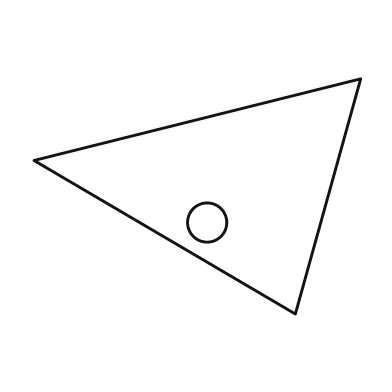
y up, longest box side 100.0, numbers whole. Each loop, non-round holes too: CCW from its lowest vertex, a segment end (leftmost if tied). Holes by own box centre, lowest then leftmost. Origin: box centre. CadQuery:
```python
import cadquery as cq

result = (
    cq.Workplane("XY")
    .moveTo(30.0, -36.0)
    .lineTo(50.0, 36.0)
    .lineTo(-50.0, 11.0)
    .close()
    .moveTo(3.0, -8.0)
    .circle(6.0)
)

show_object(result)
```